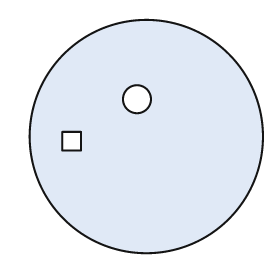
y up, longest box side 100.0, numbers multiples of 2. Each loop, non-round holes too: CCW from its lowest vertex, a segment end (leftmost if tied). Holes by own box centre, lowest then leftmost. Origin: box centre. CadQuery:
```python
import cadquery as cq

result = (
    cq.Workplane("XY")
    .moveTo(0.0, 0.0)
    .circle(50.0)
    .moveTo(-36.0, -6.0)
    .lineTo(-28.0, -6.0)
    .lineTo(-28.0, 2.0)
    .lineTo(-36.0, 2.0)
    .close()
    .moveTo(-4.0, 16.0)
    .circle(6.0)
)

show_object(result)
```